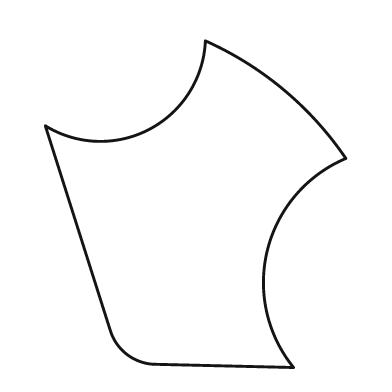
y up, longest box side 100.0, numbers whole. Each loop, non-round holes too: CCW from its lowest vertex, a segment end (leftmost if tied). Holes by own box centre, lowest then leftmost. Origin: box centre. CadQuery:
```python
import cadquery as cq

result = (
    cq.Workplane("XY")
    .moveTo(30.0, -50.0)
    .threePointArc((22.0, -14.0), (46.0, 14.0))
    .threePointArc((27.0, 35.0), (3.0, 50.0))
    .threePointArc((-14.0, 23.0), (-46.0, 24.0))
    .lineTo(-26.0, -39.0)
    .threePointArc((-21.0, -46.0), (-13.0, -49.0))
    .close()
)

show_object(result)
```